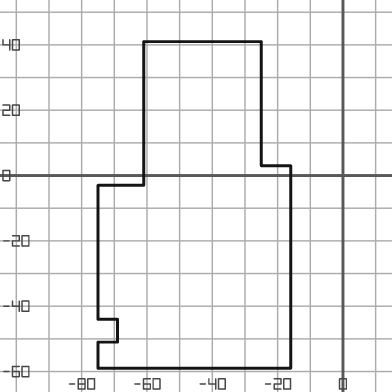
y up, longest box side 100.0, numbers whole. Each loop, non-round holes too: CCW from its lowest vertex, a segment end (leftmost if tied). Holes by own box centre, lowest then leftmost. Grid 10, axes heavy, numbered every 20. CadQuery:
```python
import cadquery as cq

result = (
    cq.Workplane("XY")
    .moveTo(-75.0, -59.0)
    .lineTo(-16.0, -59.0)
    .lineTo(-16.0, 3.0)
    .lineTo(-25.0, 3.0)
    .lineTo(-25.0, 41.0)
    .lineTo(-61.0, 41.0)
    .lineTo(-61.0, -3.0)
    .lineTo(-75.0, -3.0)
    .lineTo(-75.0, -44.0)
    .lineTo(-69.0, -44.0)
    .lineTo(-69.0, -51.0)
    .lineTo(-75.0, -51.0)
    .close()
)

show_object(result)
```